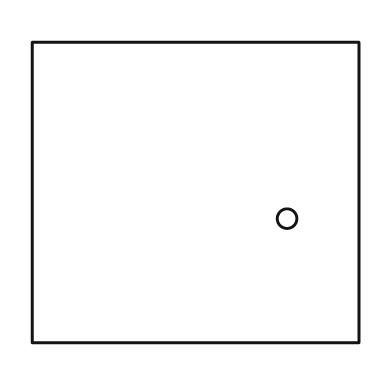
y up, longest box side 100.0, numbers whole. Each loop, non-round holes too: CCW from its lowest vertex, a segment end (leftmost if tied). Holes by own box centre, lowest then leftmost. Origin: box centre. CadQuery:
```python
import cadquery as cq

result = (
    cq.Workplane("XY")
    .moveTo(-50.0, -46.0)
    .lineTo(50.0, -46.0)
    .lineTo(50.0, 46.0)
    .lineTo(-50.0, 46.0)
    .close()
    .moveTo(28.0, -8.0)
    .circle(3.0)
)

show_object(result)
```